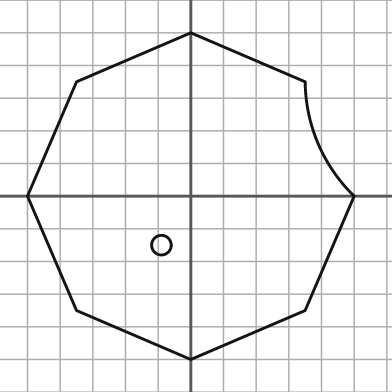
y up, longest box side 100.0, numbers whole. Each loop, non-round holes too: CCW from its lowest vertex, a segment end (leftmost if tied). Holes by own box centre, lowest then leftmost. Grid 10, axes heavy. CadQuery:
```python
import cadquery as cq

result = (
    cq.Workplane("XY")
    .moveTo(0.0, -50.0)
    .lineTo(35.0, -35.0)
    .lineTo(50.0, 0.0)
    .threePointArc((39.0, 16.0), (35.0, 35.0))
    .lineTo(0.0, 50.0)
    .lineTo(-35.0, 35.0)
    .lineTo(-50.0, 0.0)
    .lineTo(-35.0, -35.0)
    .close()
    .moveTo(-9.0, -15.0)
    .circle(3.0)
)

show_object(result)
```